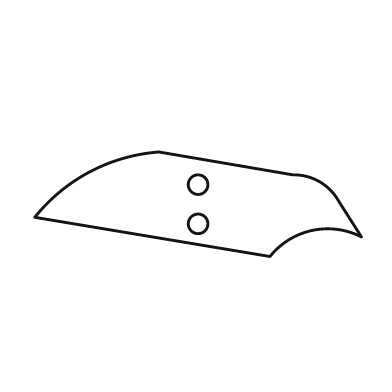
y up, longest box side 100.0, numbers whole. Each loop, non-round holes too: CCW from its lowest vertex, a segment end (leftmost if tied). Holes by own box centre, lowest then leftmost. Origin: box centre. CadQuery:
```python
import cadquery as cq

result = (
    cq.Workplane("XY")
    .moveTo(22.0, -16.0)
    .threePointArc((35.0, -8.0), (50.0, -10.0))
    .lineTo(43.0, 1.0)
    .threePointArc((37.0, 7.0), (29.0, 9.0))
    .lineTo(-12.0, 16.0)
    .threePointArc((-33.0, 10.0), (-50.0, -4.0))
    .close()
    .moveTo(0.0, -6.0)
    .circle(3.0)
    .moveTo(0.0, 6.0)
    .circle(3.0)
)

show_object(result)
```